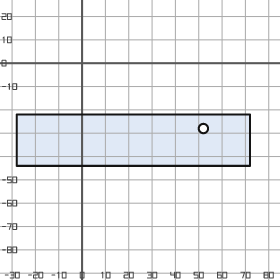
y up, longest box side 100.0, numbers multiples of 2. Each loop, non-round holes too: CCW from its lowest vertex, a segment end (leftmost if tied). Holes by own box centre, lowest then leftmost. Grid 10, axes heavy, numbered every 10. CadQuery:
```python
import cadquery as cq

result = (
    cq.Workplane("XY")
    .moveTo(-28.0, -44.0)
    .lineTo(72.0, -44.0)
    .lineTo(72.0, -22.0)
    .lineTo(-28.0, -22.0)
    .close()
    .moveTo(52.0, -28.0)
    .circle(2.0)
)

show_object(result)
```